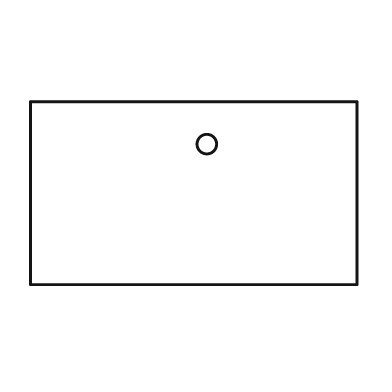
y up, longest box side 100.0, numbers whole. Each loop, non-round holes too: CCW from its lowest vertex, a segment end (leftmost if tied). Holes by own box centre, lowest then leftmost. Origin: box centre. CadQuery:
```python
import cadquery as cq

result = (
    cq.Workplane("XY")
    .moveTo(-50.0, -28.0)
    .lineTo(50.0, -28.0)
    .lineTo(50.0, 28.0)
    .lineTo(-50.0, 28.0)
    .close()
    .moveTo(4.0, 15.0)
    .circle(3.0)
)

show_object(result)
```